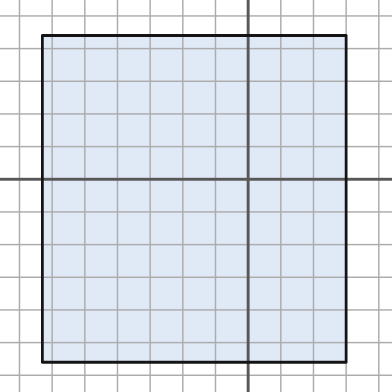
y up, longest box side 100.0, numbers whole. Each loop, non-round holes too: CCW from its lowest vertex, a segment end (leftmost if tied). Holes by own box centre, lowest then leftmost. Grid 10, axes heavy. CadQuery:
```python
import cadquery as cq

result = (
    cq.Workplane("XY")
    .moveTo(-63.0, -56.0)
    .lineTo(30.0, -56.0)
    .lineTo(30.0, 44.0)
    .lineTo(-63.0, 44.0)
    .close()
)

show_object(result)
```